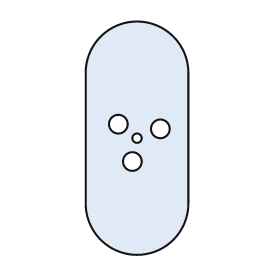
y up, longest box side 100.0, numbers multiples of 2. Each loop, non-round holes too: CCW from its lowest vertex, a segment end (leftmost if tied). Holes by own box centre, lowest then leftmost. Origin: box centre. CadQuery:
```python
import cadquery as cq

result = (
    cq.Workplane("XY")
    .moveTo(-22.0, -28.0)
    .threePointArc((0.0, -50.0), (22.0, -28.0))
    .lineTo(22.0, 28.0)
    .threePointArc((0.0, 50.0), (-22.0, 28.0))
    .close()
    .moveTo(-2.0, -10.0)
    .circle(4.0)
    .moveTo(0.0, 0.0)
    .circle(2.0)
    .moveTo(10.0, 4.0)
    .circle(4.0)
    .moveTo(-8.0, 6.0)
    .circle(4.0)
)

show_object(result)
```